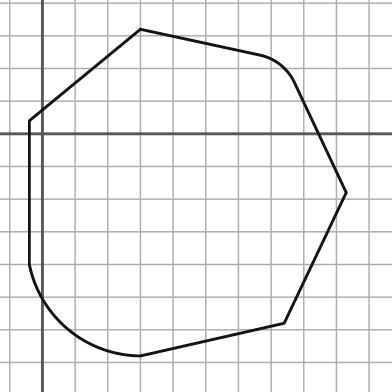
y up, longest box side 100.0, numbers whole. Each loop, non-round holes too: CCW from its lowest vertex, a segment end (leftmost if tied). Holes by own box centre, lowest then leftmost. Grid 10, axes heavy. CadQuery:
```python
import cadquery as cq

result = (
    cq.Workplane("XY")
    .moveTo(30.0, -68.0)
    .lineTo(74.0, -58.0)
    .lineTo(93.0, -18.0)
    .lineTo(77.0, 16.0)
    .threePointArc((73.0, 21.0), (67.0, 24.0))
    .lineTo(30.0, 32.0)
    .lineTo(-4.0, 4.0)
    .lineTo(-4.0, -40.0)
    .threePointArc((8.0, -60.0), (30.0, -68.0))
    .close()
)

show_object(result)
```